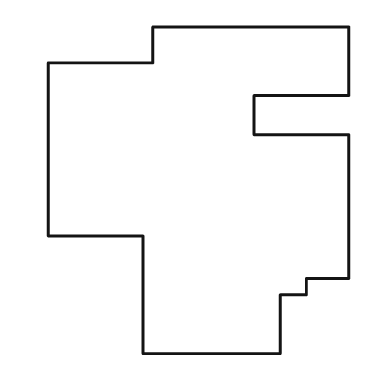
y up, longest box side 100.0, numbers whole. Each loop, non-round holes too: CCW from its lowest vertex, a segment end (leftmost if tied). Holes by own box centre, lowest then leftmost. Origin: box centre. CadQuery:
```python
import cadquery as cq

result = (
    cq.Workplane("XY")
    .moveTo(-17.0, -50.0)
    .lineTo(25.0, -50.0)
    .lineTo(25.0, -32.0)
    .lineTo(33.0, -32.0)
    .lineTo(33.0, -27.0)
    .lineTo(46.0, -27.0)
    .lineTo(46.0, 17.0)
    .lineTo(17.0, 17.0)
    .lineTo(17.0, 29.0)
    .lineTo(46.0, 29.0)
    .lineTo(46.0, 50.0)
    .lineTo(-14.0, 50.0)
    .lineTo(-14.0, 39.0)
    .lineTo(-46.0, 39.0)
    .lineTo(-46.0, -14.0)
    .lineTo(-17.0, -14.0)
    .close()
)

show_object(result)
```